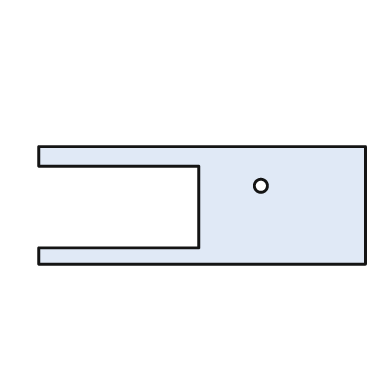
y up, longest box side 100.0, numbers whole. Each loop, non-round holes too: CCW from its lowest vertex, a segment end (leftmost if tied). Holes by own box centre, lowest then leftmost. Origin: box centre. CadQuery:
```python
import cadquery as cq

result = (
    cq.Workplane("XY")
    .moveTo(-50.0, -18.0)
    .lineTo(50.0, -18.0)
    .lineTo(50.0, 18.0)
    .lineTo(-50.0, 18.0)
    .lineTo(-50.0, 12.0)
    .lineTo(-1.0, 12.0)
    .lineTo(-1.0, -13.0)
    .lineTo(-50.0, -13.0)
    .close()
    .moveTo(18.0, 6.0)
    .circle(2.0)
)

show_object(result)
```